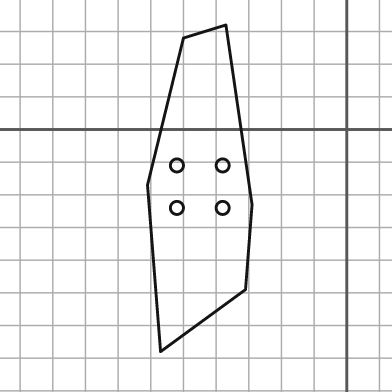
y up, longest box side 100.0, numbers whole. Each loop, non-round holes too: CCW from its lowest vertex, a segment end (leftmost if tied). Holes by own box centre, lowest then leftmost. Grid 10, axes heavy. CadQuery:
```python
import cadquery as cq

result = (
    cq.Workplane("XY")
    .moveTo(-57.0, -68.0)
    .lineTo(-31.0, -49.0)
    .lineTo(-29.0, -23.0)
    .lineTo(-37.0, 32.0)
    .lineTo(-50.0, 28.0)
    .lineTo(-61.0, -17.0)
    .close()
    .moveTo(-52.0, -24.0)
    .circle(2.0)
    .moveTo(-38.0, -24.0)
    .circle(2.0)
    .moveTo(-52.0, -11.0)
    .circle(2.0)
    .moveTo(-38.0, -11.0)
    .circle(2.0)
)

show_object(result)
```